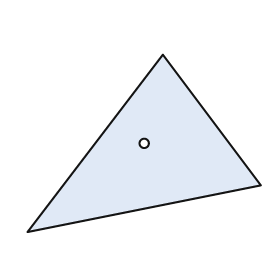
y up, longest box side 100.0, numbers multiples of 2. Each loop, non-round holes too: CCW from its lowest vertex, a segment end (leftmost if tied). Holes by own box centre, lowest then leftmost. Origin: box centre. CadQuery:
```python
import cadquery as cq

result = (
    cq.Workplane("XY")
    .moveTo(-50.0, -38.0)
    .lineTo(50.0, -18.0)
    .lineTo(8.0, 38.0)
    .close()
    .moveTo(0.0, 0.0)
    .circle(2.0)
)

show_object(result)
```